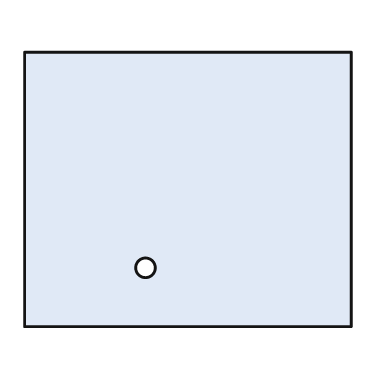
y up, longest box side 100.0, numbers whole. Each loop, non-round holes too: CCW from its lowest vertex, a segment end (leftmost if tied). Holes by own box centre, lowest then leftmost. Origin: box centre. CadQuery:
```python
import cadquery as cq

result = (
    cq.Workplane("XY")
    .moveTo(-50.0, -42.0)
    .lineTo(50.0, -42.0)
    .lineTo(50.0, 42.0)
    .lineTo(-50.0, 42.0)
    .close()
    .moveTo(-13.0, -24.0)
    .circle(3.0)
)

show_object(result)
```